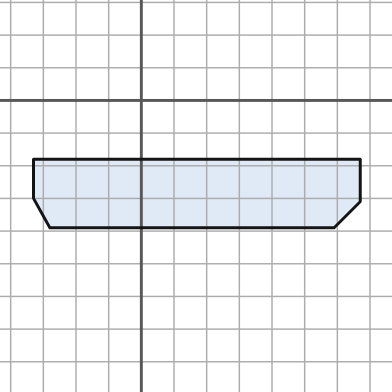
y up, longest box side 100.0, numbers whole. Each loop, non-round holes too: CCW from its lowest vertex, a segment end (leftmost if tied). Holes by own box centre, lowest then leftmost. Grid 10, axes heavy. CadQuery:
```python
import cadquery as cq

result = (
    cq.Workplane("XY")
    .moveTo(-28.0, -39.0)
    .lineTo(59.0, -39.0)
    .lineTo(67.0, -31.0)
    .lineTo(67.0, -18.0)
    .lineTo(-33.0, -18.0)
    .lineTo(-33.0, -30.0)
    .close()
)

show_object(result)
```